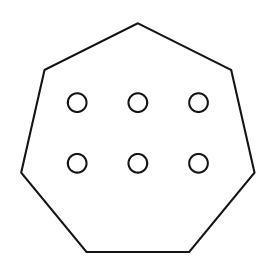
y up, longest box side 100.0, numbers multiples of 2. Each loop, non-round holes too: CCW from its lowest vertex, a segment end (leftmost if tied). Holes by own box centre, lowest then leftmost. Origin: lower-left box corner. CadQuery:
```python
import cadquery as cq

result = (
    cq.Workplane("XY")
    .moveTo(28.0, 0.0)
    .lineTo(72.0, 0.0)
    .lineTo(100.0, 34.0)
    .lineTo(90.0, 78.0)
    .lineTo(50.0, 98.0)
    .lineTo(10.0, 78.0)
    .lineTo(0.0, 34.0)
    .close()
    .moveTo(24.0, 38.0)
    .circle(4.0)
    .moveTo(50.0, 38.0)
    .circle(4.0)
    .moveTo(76.0, 38.0)
    .circle(4.0)
    .moveTo(24.0, 64.0)
    .circle(4.0)
    .moveTo(50.0, 64.0)
    .circle(4.0)
    .moveTo(76.0, 64.0)
    .circle(4.0)
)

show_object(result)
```